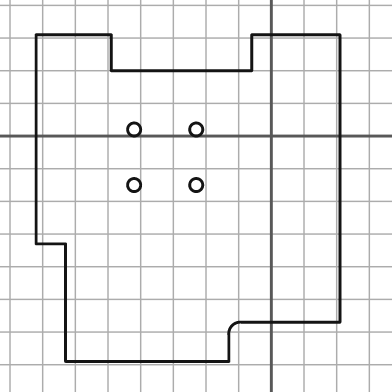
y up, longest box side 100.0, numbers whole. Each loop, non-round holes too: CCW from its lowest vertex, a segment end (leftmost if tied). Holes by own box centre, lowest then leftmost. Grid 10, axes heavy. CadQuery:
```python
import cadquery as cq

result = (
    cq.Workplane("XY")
    .moveTo(-63.0, -69.0)
    .lineTo(-13.0, -69.0)
    .lineTo(-13.0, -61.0)
    .threePointArc((-12.0, -58.0), (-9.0, -57.0))
    .lineTo(21.0, -57.0)
    .lineTo(21.0, 31.0)
    .lineTo(-6.0, 31.0)
    .lineTo(-6.0, 20.0)
    .lineTo(-49.0, 20.0)
    .lineTo(-49.0, 31.0)
    .lineTo(-72.0, 31.0)
    .lineTo(-72.0, -33.0)
    .lineTo(-63.0, -33.0)
    .close()
    .moveTo(-42.0, -15.0)
    .circle(2.0)
    .moveTo(-23.0, -15.0)
    .circle(2.0)
    .moveTo(-42.0, 2.0)
    .circle(2.0)
    .moveTo(-23.0, 2.0)
    .circle(2.0)
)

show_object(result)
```